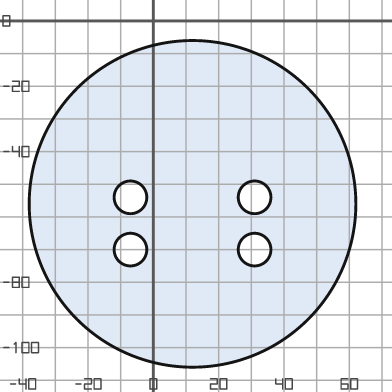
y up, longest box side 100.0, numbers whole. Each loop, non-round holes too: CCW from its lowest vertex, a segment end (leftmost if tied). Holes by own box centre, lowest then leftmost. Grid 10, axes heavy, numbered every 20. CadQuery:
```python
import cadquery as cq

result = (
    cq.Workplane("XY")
    .moveTo(12.0, -56.0)
    .circle(50.0)
    .moveTo(-7.0, -70.0)
    .circle(5.0)
    .moveTo(31.0, -70.0)
    .circle(5.0)
    .moveTo(-7.0, -54.0)
    .circle(5.0)
    .moveTo(31.0, -54.0)
    .circle(5.0)
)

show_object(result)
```